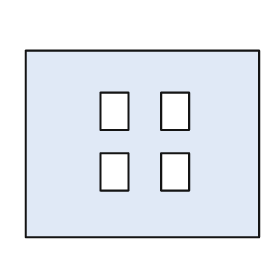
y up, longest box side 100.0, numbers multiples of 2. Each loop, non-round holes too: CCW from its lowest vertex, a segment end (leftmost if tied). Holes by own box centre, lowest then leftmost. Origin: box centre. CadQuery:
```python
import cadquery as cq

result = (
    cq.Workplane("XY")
    .moveTo(-50.0, -40.0)
    .lineTo(50.0, -40.0)
    .lineTo(50.0, 40.0)
    .lineTo(-50.0, 40.0)
    .close()
    .moveTo(-18.0, -20.0)
    .lineTo(-6.0, -20.0)
    .lineTo(-6.0, -4.0)
    .lineTo(-18.0, -4.0)
    .close()
    .moveTo(8.0, -20.0)
    .lineTo(20.0, -20.0)
    .lineTo(20.0, -4.0)
    .lineTo(8.0, -4.0)
    .close()
    .moveTo(-18.0, 6.0)
    .lineTo(-6.0, 6.0)
    .lineTo(-6.0, 22.0)
    .lineTo(-18.0, 22.0)
    .close()
    .moveTo(8.0, 6.0)
    .lineTo(20.0, 6.0)
    .lineTo(20.0, 22.0)
    .lineTo(8.0, 22.0)
    .close()
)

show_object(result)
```